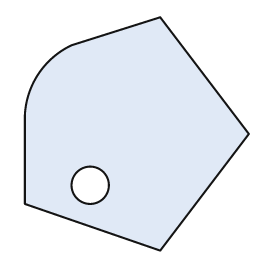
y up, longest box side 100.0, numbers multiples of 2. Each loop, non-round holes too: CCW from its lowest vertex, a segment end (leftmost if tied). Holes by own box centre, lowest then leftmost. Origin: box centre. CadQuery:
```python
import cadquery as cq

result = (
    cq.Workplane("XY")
    .moveTo(10.0, -50.0)
    .lineTo(48.0, 0.0)
    .lineTo(10.0, 50.0)
    .lineTo(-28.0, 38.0)
    .threePointArc((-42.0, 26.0), (-48.0, 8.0))
    .lineTo(-48.0, -30.0)
    .close()
    .moveTo(-20.0, -22.0)
    .circle(8.0)
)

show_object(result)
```